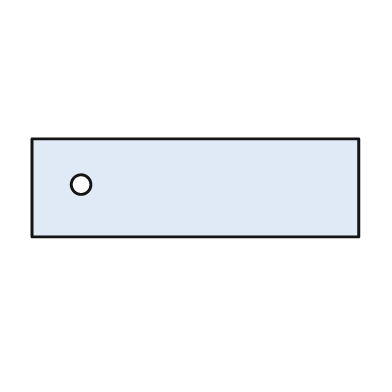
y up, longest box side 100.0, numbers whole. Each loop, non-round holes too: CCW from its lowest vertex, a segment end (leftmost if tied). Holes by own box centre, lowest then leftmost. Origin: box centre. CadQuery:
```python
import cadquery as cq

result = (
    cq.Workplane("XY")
    .moveTo(-50.0, -15.0)
    .lineTo(50.0, -15.0)
    .lineTo(50.0, 15.0)
    .lineTo(-50.0, 15.0)
    .close()
    .moveTo(-35.0, 1.0)
    .circle(3.0)
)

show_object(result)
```